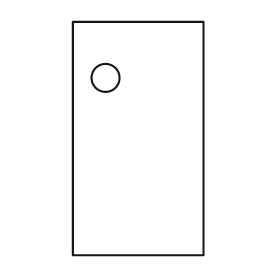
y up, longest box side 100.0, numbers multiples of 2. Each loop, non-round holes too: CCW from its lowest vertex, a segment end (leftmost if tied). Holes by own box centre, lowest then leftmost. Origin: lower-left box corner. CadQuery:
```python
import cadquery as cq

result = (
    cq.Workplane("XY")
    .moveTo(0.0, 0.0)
    .lineTo(56.0, 0.0)
    .lineTo(56.0, 100.0)
    .lineTo(0.0, 100.0)
    .close()
    .moveTo(14.0, 76.0)
    .circle(6.0)
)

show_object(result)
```